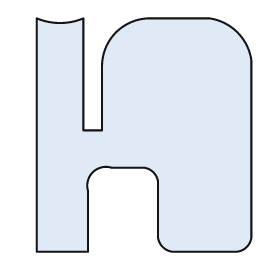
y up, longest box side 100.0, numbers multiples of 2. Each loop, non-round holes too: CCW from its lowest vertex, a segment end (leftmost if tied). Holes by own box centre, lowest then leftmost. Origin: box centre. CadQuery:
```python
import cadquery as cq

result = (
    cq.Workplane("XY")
    .moveTo(-46.0, -50.0)
    .lineTo(-24.0, -50.0)
    .lineTo(-24.0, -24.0)
    .threePointArc((-22.0, -16.0), (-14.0, -14.0))
    .lineTo(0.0, -14.0)
    .threePointArc((4.0, -16.0), (6.0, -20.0))
    .lineTo(6.0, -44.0)
    .threePointArc((8.0, -48.0), (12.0, -50.0))
    .lineTo(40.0, -50.0)
    .threePointArc((44.0, -48.0), (46.0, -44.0))
    .lineTo(46.0, 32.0)
    .threePointArc((40.0, 44.0), (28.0, 50.0))
    .lineTo(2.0, 50.0)
    .threePointArc((-12.0, 44.0), (-18.0, 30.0))
    .lineTo(-18.0, 2.0)
    .lineTo(-26.0, 2.0)
    .lineTo(-26.0, 50.0)
    .threePointArc((-36.0, 48.0), (-46.0, 50.0))
    .close()
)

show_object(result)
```